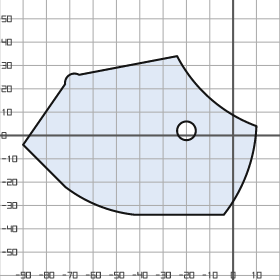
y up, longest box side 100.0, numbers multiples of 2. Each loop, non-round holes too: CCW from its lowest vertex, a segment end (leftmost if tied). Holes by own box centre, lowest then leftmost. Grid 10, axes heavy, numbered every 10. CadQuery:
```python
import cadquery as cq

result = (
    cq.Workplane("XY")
    .moveTo(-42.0, -34.0)
    .lineTo(-4.0, -34.0)
    .threePointArc((6.0, -16.0), (10.0, 4.0))
    .threePointArc((-10.0, 16.0), (-24.0, 34.0))
    .lineTo(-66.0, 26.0)
    .threePointArc((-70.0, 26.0), (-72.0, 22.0))
    .lineTo(-90.0, -4.0)
    .lineTo(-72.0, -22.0)
    .threePointArc((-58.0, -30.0), (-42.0, -34.0))
    .close()
    .moveTo(-20.0, 2.0)
    .circle(4.0)
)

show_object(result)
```